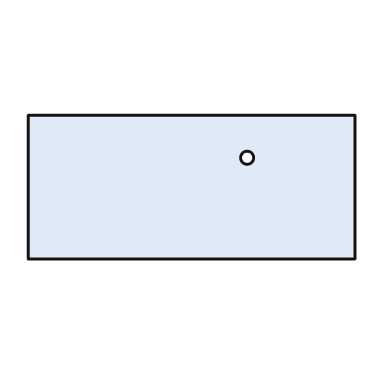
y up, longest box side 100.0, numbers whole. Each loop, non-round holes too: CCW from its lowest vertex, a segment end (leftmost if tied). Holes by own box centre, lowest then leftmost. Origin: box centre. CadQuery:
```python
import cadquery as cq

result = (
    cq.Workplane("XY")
    .moveTo(-50.0, -22.0)
    .lineTo(50.0, -22.0)
    .lineTo(50.0, 22.0)
    .lineTo(-50.0, 22.0)
    .close()
    .moveTo(17.0, 9.0)
    .circle(2.0)
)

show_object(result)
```